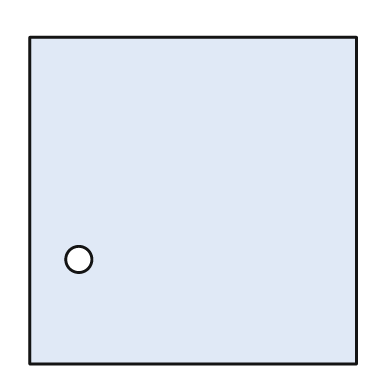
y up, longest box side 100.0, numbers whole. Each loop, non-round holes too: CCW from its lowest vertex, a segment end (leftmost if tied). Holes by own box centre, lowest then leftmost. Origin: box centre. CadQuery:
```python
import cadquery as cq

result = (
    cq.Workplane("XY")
    .moveTo(-50.0, -50.0)
    .lineTo(50.0, -50.0)
    .lineTo(50.0, 50.0)
    .lineTo(-50.0, 50.0)
    .close()
    .moveTo(-35.0, -18.0)
    .circle(4.0)
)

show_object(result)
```